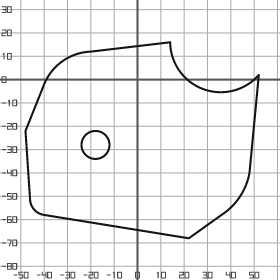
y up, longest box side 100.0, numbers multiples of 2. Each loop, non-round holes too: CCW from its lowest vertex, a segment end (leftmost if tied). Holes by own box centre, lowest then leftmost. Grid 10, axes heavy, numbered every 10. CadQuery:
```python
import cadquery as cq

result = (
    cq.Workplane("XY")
    .moveTo(22.0, -68.0)
    .lineTo(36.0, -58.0)
    .threePointArc((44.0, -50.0), (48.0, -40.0))
    .lineTo(52.0, 2.0)
    .threePointArc((28.0, -4.0), (14.0, 16.0))
    .lineTo(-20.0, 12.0)
    .threePointArc((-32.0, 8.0), (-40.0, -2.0))
    .lineTo(-48.0, -22.0)
    .lineTo(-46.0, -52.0)
    .threePointArc((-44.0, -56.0), (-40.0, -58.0))
    .close()
    .moveTo(-18.0, -28.0)
    .circle(6.0)
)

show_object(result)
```